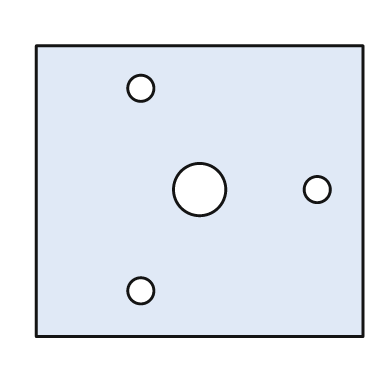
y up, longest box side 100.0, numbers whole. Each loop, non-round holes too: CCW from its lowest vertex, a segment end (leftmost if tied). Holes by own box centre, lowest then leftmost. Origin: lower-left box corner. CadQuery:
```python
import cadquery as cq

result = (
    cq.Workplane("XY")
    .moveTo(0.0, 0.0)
    .lineTo(100.0, 0.0)
    .lineTo(100.0, 89.0)
    .lineTo(0.0, 89.0)
    .close()
    .moveTo(32.0, 14.0)
    .circle(4.0)
    .moveTo(50.0, 45.0)
    .circle(8.0)
    .moveTo(86.0, 45.0)
    .circle(4.0)
    .moveTo(32.0, 76.0)
    .circle(4.0)
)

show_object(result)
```